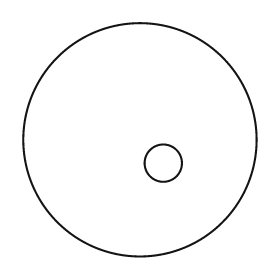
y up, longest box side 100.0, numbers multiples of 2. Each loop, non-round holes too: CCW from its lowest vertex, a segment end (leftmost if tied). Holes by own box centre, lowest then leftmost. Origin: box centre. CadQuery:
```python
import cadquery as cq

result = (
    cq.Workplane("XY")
    .moveTo(0.0, 0.0)
    .circle(50.0)
    .moveTo(10.0, -10.0)
    .circle(8.0)
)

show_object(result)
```